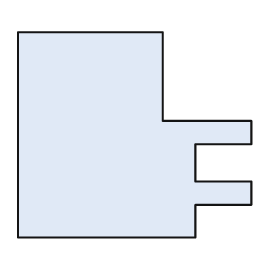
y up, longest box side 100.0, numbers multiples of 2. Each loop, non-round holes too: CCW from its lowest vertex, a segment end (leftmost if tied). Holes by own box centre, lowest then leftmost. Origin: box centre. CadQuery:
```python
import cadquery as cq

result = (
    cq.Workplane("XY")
    .moveTo(-50.0, -44.0)
    .lineTo(26.0, -44.0)
    .lineTo(26.0, -30.0)
    .lineTo(50.0, -30.0)
    .lineTo(50.0, -20.0)
    .lineTo(26.0, -20.0)
    .lineTo(26.0, -4.0)
    .lineTo(50.0, -4.0)
    .lineTo(50.0, 6.0)
    .lineTo(12.0, 6.0)
    .lineTo(12.0, 44.0)
    .lineTo(-50.0, 44.0)
    .close()
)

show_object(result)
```